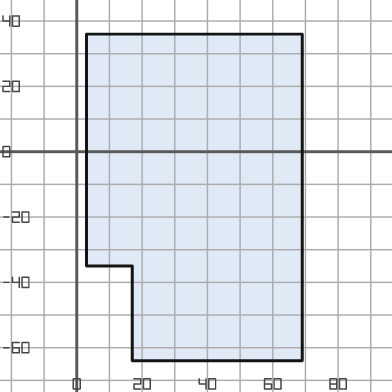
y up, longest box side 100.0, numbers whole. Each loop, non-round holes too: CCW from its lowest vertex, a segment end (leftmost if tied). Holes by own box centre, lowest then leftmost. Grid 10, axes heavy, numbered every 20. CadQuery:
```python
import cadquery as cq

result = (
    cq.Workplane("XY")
    .moveTo(17.0, -64.0)
    .lineTo(69.0, -64.0)
    .lineTo(69.0, 36.0)
    .lineTo(3.0, 36.0)
    .lineTo(3.0, -35.0)
    .lineTo(17.0, -35.0)
    .close()
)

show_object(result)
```